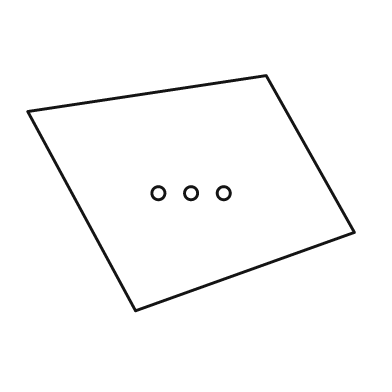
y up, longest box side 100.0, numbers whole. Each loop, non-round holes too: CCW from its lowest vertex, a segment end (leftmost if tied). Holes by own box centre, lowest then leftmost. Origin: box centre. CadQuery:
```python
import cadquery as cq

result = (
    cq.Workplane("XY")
    .moveTo(-17.0, -36.0)
    .lineTo(50.0, -12.0)
    .lineTo(23.0, 36.0)
    .lineTo(-50.0, 25.0)
    .close()
    .moveTo(-10.0, 0.0)
    .circle(2.0)
    .moveTo(0.0, 0.0)
    .circle(2.0)
    .moveTo(10.0, 0.0)
    .circle(2.0)
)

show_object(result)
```